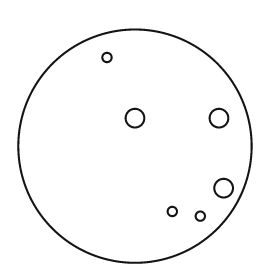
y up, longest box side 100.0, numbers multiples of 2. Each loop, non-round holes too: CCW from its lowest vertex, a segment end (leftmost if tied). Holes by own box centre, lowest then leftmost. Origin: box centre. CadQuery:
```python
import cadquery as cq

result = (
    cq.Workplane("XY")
    .moveTo(0.0, 0.0)
    .circle(50.0)
    .moveTo(28.0, -30.0)
    .circle(2.0)
    .moveTo(16.0, -28.0)
    .circle(2.0)
    .moveTo(38.0, -18.0)
    .circle(4.0)
    .moveTo(0.0, 12.0)
    .circle(4.0)
    .moveTo(36.0, 12.0)
    .circle(4.0)
    .moveTo(-12.0, 38.0)
    .circle(2.0)
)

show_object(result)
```